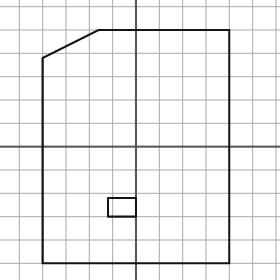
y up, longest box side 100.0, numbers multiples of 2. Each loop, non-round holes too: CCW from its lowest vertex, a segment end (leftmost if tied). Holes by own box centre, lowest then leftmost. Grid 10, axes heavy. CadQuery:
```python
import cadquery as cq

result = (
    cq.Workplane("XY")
    .moveTo(-40.0, -50.0)
    .lineTo(40.0, -50.0)
    .lineTo(40.0, 50.0)
    .lineTo(-16.0, 50.0)
    .lineTo(-40.0, 38.0)
    .close()
    .moveTo(-12.0, -30.0)
    .lineTo(0.0, -30.0)
    .lineTo(0.0, -22.0)
    .lineTo(-12.0, -22.0)
    .close()
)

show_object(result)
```